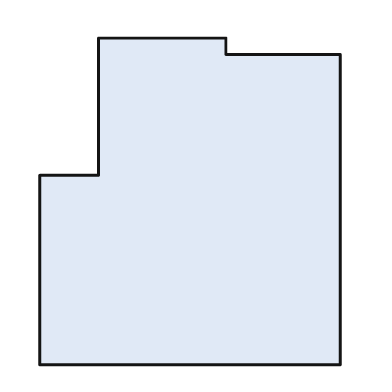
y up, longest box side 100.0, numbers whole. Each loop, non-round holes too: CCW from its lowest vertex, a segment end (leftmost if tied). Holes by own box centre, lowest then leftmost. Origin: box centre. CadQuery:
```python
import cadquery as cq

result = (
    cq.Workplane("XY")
    .moveTo(-46.0, -50.0)
    .lineTo(46.0, -50.0)
    .lineTo(46.0, 45.0)
    .lineTo(11.0, 45.0)
    .lineTo(11.0, 50.0)
    .lineTo(-28.0, 50.0)
    .lineTo(-28.0, 8.0)
    .lineTo(-46.0, 8.0)
    .close()
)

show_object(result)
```